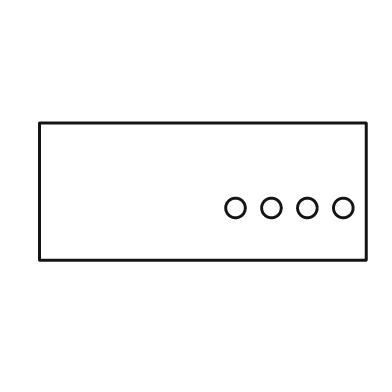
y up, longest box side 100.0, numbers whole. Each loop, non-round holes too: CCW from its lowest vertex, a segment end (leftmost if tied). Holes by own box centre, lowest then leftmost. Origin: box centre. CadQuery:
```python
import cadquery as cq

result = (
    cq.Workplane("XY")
    .moveTo(-50.0, -21.0)
    .lineTo(50.0, -21.0)
    .lineTo(50.0, 21.0)
    .lineTo(-50.0, 21.0)
    .close()
    .moveTo(10.0, -5.0)
    .circle(3.0)
    .moveTo(21.0, -5.0)
    .circle(3.0)
    .moveTo(32.0, -5.0)
    .circle(3.0)
    .moveTo(43.0, -5.0)
    .circle(3.0)
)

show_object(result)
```